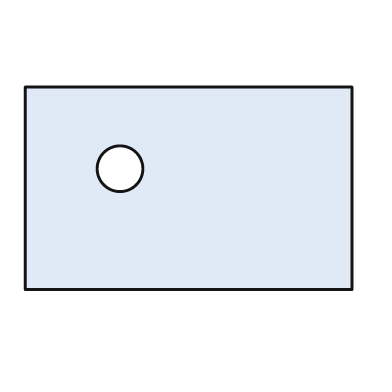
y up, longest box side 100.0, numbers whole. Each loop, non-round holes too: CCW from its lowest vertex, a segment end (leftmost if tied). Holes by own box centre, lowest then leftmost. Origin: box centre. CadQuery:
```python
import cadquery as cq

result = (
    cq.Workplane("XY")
    .moveTo(-50.0, -31.0)
    .lineTo(50.0, -31.0)
    .lineTo(50.0, 31.0)
    .lineTo(-50.0, 31.0)
    .close()
    .moveTo(-21.0, 6.0)
    .circle(7.0)
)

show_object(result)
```